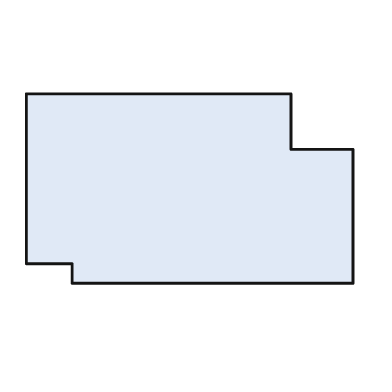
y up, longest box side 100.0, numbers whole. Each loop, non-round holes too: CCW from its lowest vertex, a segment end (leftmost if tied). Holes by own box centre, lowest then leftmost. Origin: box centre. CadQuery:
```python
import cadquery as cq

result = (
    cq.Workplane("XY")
    .moveTo(-36.0, -29.0)
    .lineTo(50.0, -29.0)
    .lineTo(50.0, 12.0)
    .lineTo(31.0, 12.0)
    .lineTo(31.0, 29.0)
    .lineTo(-50.0, 29.0)
    .lineTo(-50.0, -23.0)
    .lineTo(-36.0, -23.0)
    .close()
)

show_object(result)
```